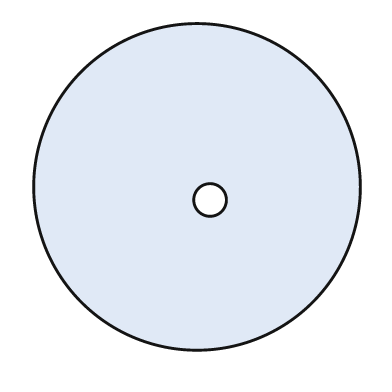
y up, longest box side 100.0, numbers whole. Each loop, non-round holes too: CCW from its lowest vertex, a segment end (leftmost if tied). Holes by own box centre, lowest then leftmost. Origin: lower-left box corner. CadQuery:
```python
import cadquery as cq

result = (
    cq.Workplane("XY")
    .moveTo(50.0, 50.0)
    .circle(50.0)
    .moveTo(54.0, 46.0)
    .circle(5.0)
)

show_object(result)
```